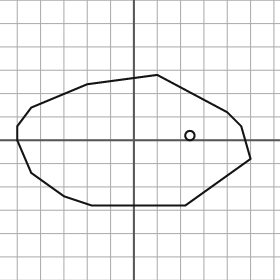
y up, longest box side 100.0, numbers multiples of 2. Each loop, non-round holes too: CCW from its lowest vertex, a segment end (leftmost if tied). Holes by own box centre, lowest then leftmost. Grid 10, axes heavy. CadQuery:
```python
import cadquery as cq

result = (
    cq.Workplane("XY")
    .moveTo(-18.0, -28.0)
    .lineTo(22.0, -28.0)
    .lineTo(50.0, -8.0)
    .lineTo(46.0, 6.0)
    .lineTo(40.0, 12.0)
    .lineTo(10.0, 28.0)
    .lineTo(-20.0, 24.0)
    .lineTo(-44.0, 14.0)
    .lineTo(-50.0, 6.0)
    .lineTo(-50.0, 0.0)
    .lineTo(-44.0, -14.0)
    .lineTo(-30.0, -24.0)
    .close()
    .moveTo(24.0, 2.0)
    .circle(2.0)
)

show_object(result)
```